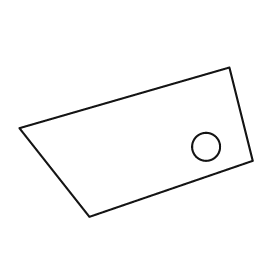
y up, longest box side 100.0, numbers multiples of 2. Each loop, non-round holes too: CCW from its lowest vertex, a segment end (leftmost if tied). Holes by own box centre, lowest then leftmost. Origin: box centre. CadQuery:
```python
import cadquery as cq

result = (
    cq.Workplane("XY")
    .moveTo(-20.0, -32.0)
    .lineTo(50.0, -8.0)
    .lineTo(40.0, 32.0)
    .lineTo(-50.0, 6.0)
    .close()
    .moveTo(30.0, -2.0)
    .circle(6.0)
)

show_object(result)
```